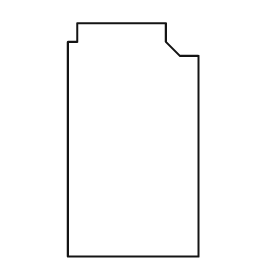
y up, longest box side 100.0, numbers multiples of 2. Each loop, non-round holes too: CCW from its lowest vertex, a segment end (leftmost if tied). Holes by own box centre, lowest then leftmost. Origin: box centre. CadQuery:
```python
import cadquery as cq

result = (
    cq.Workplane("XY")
    .moveTo(-28.0, -50.0)
    .lineTo(28.0, -50.0)
    .lineTo(28.0, 36.0)
    .lineTo(20.0, 36.0)
    .lineTo(14.0, 42.0)
    .lineTo(14.0, 50.0)
    .lineTo(-24.0, 50.0)
    .lineTo(-24.0, 42.0)
    .lineTo(-28.0, 42.0)
    .close()
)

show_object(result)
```